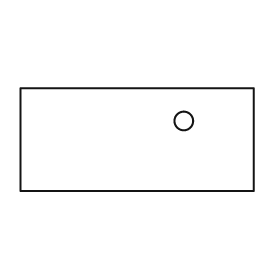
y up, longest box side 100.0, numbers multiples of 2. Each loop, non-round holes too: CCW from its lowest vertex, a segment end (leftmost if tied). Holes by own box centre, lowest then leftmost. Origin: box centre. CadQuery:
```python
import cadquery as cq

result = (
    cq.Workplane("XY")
    .moveTo(-50.0, -22.0)
    .lineTo(50.0, -22.0)
    .lineTo(50.0, 22.0)
    .lineTo(-50.0, 22.0)
    .close()
    .moveTo(20.0, 8.0)
    .circle(4.0)
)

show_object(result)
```